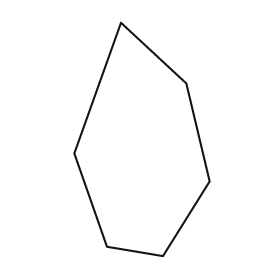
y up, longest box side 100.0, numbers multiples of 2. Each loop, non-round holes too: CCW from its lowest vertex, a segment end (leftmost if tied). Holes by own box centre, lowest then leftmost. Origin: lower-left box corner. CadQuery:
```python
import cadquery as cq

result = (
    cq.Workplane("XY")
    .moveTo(38.0, 0.0)
    .lineTo(58.0, 32.0)
    .lineTo(48.0, 74.0)
    .lineTo(20.0, 100.0)
    .lineTo(0.0, 44.0)
    .lineTo(14.0, 4.0)
    .close()
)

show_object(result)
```